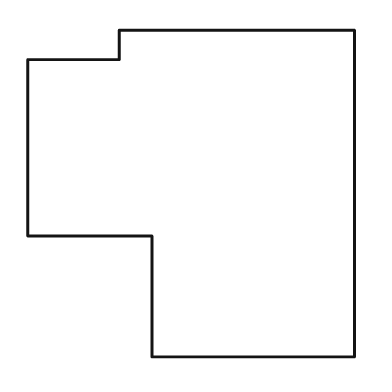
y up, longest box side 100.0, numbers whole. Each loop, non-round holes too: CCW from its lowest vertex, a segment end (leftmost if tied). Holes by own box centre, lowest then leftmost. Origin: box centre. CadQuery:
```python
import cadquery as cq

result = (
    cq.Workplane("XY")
    .moveTo(-12.0, -50.0)
    .lineTo(50.0, -50.0)
    .lineTo(50.0, 50.0)
    .lineTo(-22.0, 50.0)
    .lineTo(-22.0, 41.0)
    .lineTo(-50.0, 41.0)
    .lineTo(-50.0, -13.0)
    .lineTo(-12.0, -13.0)
    .close()
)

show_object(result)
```